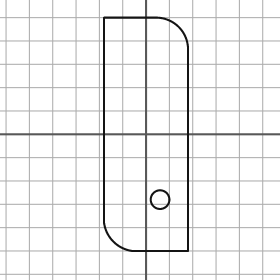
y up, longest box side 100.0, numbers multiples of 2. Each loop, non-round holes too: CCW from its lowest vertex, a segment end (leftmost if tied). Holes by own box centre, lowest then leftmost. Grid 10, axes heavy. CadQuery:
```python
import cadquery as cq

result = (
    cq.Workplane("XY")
    .moveTo(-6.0, -50.0)
    .lineTo(18.0, -50.0)
    .lineTo(18.0, 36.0)
    .threePointArc((14.0, 46.0), (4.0, 50.0))
    .lineTo(-18.0, 50.0)
    .lineTo(-18.0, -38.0)
    .threePointArc((-14.0, -46.0), (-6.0, -50.0))
    .close()
    .moveTo(6.0, -28.0)
    .circle(4.0)
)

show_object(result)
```